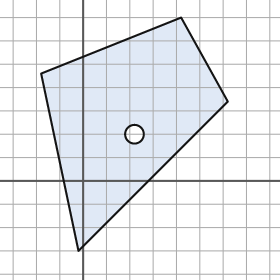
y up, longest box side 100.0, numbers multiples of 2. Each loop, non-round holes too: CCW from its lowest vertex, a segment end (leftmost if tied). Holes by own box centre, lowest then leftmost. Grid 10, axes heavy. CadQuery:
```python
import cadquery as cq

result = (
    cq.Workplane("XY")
    .moveTo(-2.0, -30.0)
    .lineTo(62.0, 34.0)
    .lineTo(42.0, 70.0)
    .lineTo(-18.0, 46.0)
    .close()
    .moveTo(22.0, 20.0)
    .circle(4.0)
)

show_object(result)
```